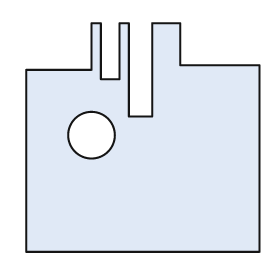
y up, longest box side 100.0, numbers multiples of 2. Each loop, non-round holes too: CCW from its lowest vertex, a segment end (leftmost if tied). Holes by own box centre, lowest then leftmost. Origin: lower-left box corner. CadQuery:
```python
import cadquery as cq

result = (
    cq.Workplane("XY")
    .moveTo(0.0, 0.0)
    .lineTo(100.0, 0.0)
    .lineTo(100.0, 80.0)
    .lineTo(66.0, 80.0)
    .lineTo(66.0, 98.0)
    .lineTo(54.0, 98.0)
    .lineTo(54.0, 58.0)
    .lineTo(44.0, 58.0)
    .lineTo(44.0, 98.0)
    .lineTo(40.0, 98.0)
    .lineTo(40.0, 74.0)
    .lineTo(32.0, 74.0)
    .lineTo(32.0, 98.0)
    .lineTo(28.0, 98.0)
    .lineTo(28.0, 78.0)
    .lineTo(0.0, 78.0)
    .close()
    .moveTo(28.0, 50.0)
    .circle(10.0)
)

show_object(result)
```